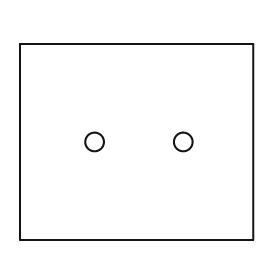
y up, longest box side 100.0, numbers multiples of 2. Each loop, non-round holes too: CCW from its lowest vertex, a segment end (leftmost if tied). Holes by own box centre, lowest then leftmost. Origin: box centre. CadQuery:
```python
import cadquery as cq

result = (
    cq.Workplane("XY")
    .moveTo(-50.0, -42.0)
    .lineTo(50.0, -42.0)
    .lineTo(50.0, 42.0)
    .lineTo(-50.0, 42.0)
    .close()
    .moveTo(-18.0, 0.0)
    .circle(4.0)
    .moveTo(20.0, 0.0)
    .circle(4.0)
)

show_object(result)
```